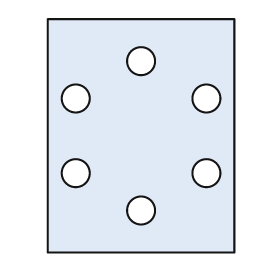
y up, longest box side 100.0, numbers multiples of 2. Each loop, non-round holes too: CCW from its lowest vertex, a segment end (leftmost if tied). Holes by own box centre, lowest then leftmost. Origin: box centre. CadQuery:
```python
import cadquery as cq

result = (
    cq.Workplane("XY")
    .moveTo(-40.0, -50.0)
    .lineTo(40.0, -50.0)
    .lineTo(40.0, 50.0)
    .lineTo(-40.0, 50.0)
    .close()
    .moveTo(0.0, -32.0)
    .circle(6.0)
    .moveTo(-28.0, -16.0)
    .circle(6.0)
    .moveTo(28.0, -16.0)
    .circle(6.0)
    .moveTo(-28.0, 16.0)
    .circle(6.0)
    .moveTo(28.0, 16.0)
    .circle(6.0)
    .moveTo(0.0, 32.0)
    .circle(6.0)
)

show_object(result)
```